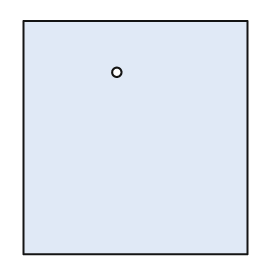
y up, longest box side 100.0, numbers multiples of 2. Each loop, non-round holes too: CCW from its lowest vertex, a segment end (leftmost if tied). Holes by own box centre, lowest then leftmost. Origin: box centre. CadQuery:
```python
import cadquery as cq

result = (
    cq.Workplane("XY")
    .moveTo(-48.0, -50.0)
    .lineTo(48.0, -50.0)
    .lineTo(48.0, 50.0)
    .lineTo(-48.0, 50.0)
    .close()
    .moveTo(-8.0, 28.0)
    .circle(2.0)
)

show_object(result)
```